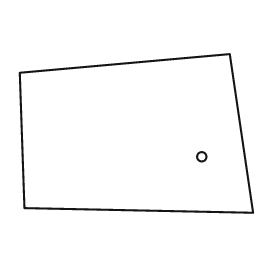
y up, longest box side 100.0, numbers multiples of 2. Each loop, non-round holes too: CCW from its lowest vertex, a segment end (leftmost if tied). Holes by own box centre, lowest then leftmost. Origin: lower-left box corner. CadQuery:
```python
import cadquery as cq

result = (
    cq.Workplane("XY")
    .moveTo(100.0, 0.0)
    .lineTo(90.0, 68.0)
    .lineTo(0.0, 60.0)
    .lineTo(2.0, 2.0)
    .close()
    .moveTo(78.0, 24.0)
    .circle(2.0)
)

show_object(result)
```